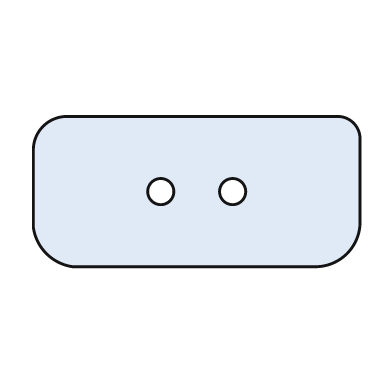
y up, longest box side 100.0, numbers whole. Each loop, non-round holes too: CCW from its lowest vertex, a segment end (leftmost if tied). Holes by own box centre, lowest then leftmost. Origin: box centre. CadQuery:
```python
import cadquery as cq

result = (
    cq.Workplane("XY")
    .moveTo(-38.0, -23.0)
    .lineTo(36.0, -23.0)
    .threePointArc((46.0, -19.0), (50.0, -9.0))
    .lineTo(50.0, 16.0)
    .threePointArc((48.0, 21.0), (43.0, 23.0))
    .lineTo(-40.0, 23.0)
    .threePointArc((-47.0, 20.0), (-50.0, 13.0))
    .lineTo(-50.0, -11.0)
    .threePointArc((-46.0, -19.0), (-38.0, -23.0))
    .close()
    .moveTo(-11.0, 0.0)
    .circle(4.0)
    .moveTo(11.0, 0.0)
    .circle(4.0)
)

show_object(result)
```